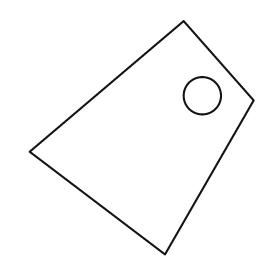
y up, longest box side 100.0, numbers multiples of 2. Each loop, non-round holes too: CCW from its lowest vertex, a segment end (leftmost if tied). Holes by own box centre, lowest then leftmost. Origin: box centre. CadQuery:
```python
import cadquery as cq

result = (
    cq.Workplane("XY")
    .moveTo(10.0, -50.0)
    .lineTo(48.0, 16.0)
    .lineTo(18.0, 50.0)
    .lineTo(-48.0, -6.0)
    .close()
    .moveTo(26.0, 18.0)
    .circle(8.0)
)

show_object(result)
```